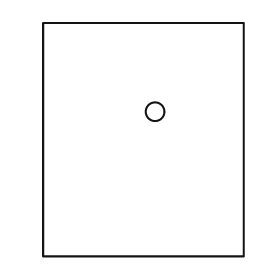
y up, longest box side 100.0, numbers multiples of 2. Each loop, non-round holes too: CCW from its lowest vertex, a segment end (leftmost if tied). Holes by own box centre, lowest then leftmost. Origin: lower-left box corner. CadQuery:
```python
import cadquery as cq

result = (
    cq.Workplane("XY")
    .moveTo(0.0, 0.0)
    .lineTo(86.0, 0.0)
    .lineTo(86.0, 100.0)
    .lineTo(0.0, 100.0)
    .close()
    .moveTo(48.0, 62.0)
    .circle(4.0)
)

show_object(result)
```